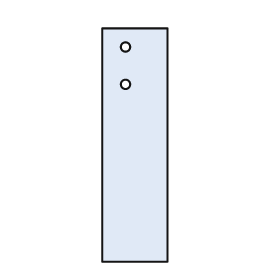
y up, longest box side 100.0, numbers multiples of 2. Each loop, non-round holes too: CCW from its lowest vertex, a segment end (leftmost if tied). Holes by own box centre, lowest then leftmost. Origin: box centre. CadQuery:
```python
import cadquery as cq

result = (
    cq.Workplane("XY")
    .moveTo(-14.0, -50.0)
    .lineTo(14.0, -50.0)
    .lineTo(14.0, 50.0)
    .lineTo(-14.0, 50.0)
    .close()
    .moveTo(-4.0, 26.0)
    .circle(2.0)
    .moveTo(-4.0, 42.0)
    .circle(2.0)
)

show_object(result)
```